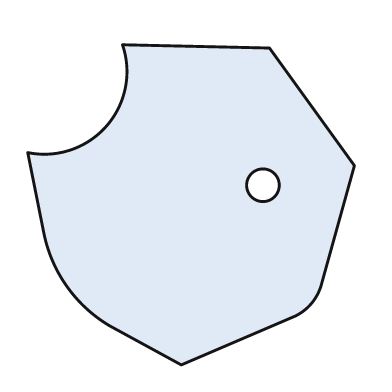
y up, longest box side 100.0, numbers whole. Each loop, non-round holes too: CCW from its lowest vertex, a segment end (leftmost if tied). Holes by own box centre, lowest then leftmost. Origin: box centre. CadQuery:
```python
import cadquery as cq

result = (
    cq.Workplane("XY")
    .moveTo(-3.0, -49.0)
    .lineTo(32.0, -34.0)
    .threePointArc((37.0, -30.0), (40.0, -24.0))
    .lineTo(50.0, 12.0)
    .lineTo(24.0, 48.0)
    .lineTo(-21.0, 49.0)
    .threePointArc((-26.0, 24.0), (-50.0, 16.0))
    .lineTo(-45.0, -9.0)
    .threePointArc((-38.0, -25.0), (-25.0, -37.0))
    .close()
    .moveTo(22.0, 6.0)
    .circle(5.0)
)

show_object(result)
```